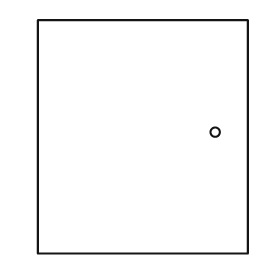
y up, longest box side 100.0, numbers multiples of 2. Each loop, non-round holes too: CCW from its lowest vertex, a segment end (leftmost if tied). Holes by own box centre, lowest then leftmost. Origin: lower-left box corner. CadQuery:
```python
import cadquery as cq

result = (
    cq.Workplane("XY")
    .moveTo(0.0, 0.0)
    .lineTo(90.0, 0.0)
    .lineTo(90.0, 100.0)
    .lineTo(0.0, 100.0)
    .close()
    .moveTo(76.0, 52.0)
    .circle(2.0)
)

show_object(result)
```